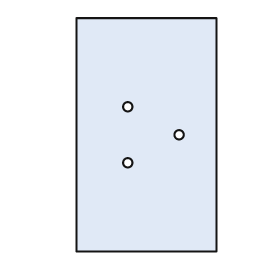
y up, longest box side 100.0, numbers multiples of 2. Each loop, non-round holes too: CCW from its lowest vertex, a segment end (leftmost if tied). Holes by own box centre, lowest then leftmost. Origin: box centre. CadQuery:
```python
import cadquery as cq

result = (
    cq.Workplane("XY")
    .moveTo(-30.0, -50.0)
    .lineTo(30.0, -50.0)
    .lineTo(30.0, 50.0)
    .lineTo(-30.0, 50.0)
    .close()
    .moveTo(-8.0, -12.0)
    .circle(2.0)
    .moveTo(14.0, 0.0)
    .circle(2.0)
    .moveTo(-8.0, 12.0)
    .circle(2.0)
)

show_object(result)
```